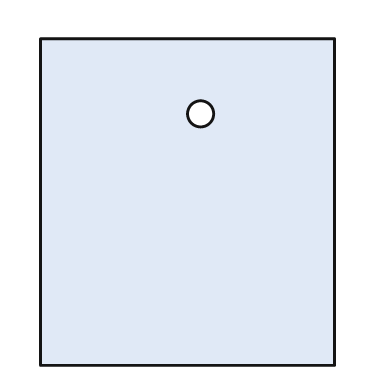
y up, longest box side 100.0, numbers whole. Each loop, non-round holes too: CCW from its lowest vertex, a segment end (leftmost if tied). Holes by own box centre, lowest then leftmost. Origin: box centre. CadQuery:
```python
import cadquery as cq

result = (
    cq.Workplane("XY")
    .moveTo(-45.0, -50.0)
    .lineTo(45.0, -50.0)
    .lineTo(45.0, 50.0)
    .lineTo(-45.0, 50.0)
    .close()
    .moveTo(4.0, 27.0)
    .circle(4.0)
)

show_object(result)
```